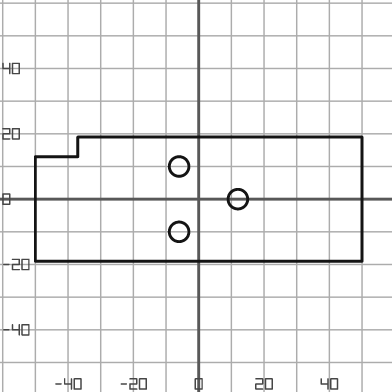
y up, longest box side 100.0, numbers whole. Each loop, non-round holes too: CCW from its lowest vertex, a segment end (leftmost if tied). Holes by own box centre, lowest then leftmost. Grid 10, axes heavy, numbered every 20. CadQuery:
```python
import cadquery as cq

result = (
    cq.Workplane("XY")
    .moveTo(-50.0, -19.0)
    .lineTo(50.0, -19.0)
    .lineTo(50.0, 19.0)
    .lineTo(-37.0, 19.0)
    .lineTo(-37.0, 13.0)
    .lineTo(-50.0, 13.0)
    .close()
    .moveTo(-6.0, -10.0)
    .circle(3.0)
    .moveTo(12.0, 0.0)
    .circle(3.0)
    .moveTo(-6.0, 10.0)
    .circle(3.0)
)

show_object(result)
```